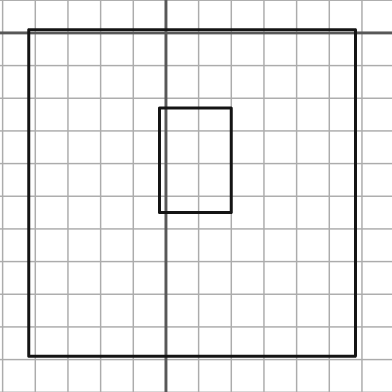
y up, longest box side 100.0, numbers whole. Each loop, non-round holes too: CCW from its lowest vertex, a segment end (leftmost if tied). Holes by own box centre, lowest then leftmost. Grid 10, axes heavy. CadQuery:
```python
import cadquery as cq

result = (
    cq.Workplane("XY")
    .moveTo(-42.0, -99.0)
    .lineTo(58.0, -99.0)
    .lineTo(58.0, 1.0)
    .lineTo(-42.0, 1.0)
    .close()
    .moveTo(-2.0, -55.0)
    .lineTo(20.0, -55.0)
    .lineTo(20.0, -23.0)
    .lineTo(-2.0, -23.0)
    .close()
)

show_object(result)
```